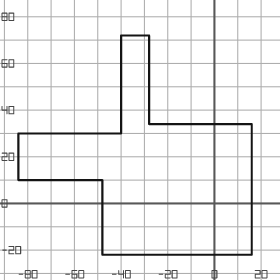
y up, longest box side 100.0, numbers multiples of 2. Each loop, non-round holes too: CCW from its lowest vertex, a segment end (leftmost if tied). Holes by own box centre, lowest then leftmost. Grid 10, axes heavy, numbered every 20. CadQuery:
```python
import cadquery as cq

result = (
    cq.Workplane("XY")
    .moveTo(-48.0, -22.0)
    .lineTo(16.0, -22.0)
    .lineTo(16.0, 34.0)
    .lineTo(-28.0, 34.0)
    .lineTo(-28.0, 72.0)
    .lineTo(-40.0, 72.0)
    .lineTo(-40.0, 30.0)
    .lineTo(-84.0, 30.0)
    .lineTo(-84.0, 10.0)
    .lineTo(-48.0, 10.0)
    .close()
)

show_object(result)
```